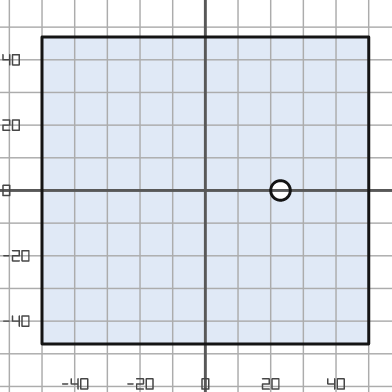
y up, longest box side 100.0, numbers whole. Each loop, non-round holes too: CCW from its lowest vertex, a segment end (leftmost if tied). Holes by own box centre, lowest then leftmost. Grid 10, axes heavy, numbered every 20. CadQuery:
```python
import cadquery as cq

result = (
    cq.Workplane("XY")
    .moveTo(-50.0, -47.0)
    .lineTo(50.0, -47.0)
    .lineTo(50.0, 47.0)
    .lineTo(-50.0, 47.0)
    .close()
    .moveTo(23.0, 0.0)
    .circle(3.0)
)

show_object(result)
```